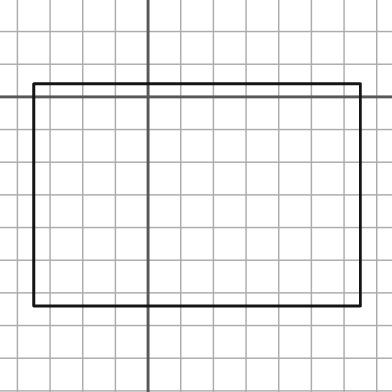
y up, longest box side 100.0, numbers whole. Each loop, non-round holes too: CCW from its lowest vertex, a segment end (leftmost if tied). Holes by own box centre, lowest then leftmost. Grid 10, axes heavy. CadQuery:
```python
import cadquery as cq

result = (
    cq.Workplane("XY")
    .moveTo(-35.0, -64.0)
    .lineTo(65.0, -64.0)
    .lineTo(65.0, 4.0)
    .lineTo(-35.0, 4.0)
    .close()
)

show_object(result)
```